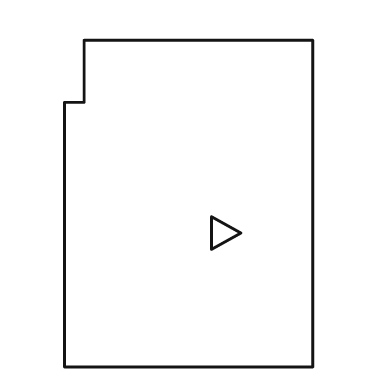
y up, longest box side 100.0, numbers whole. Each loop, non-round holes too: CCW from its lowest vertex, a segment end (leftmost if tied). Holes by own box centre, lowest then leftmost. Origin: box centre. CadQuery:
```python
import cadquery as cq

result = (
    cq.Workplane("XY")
    .moveTo(-38.0, -50.0)
    .lineTo(38.0, -50.0)
    .lineTo(38.0, 50.0)
    .lineTo(-32.0, 50.0)
    .lineTo(-32.0, 31.0)
    .lineTo(-38.0, 31.0)
    .close()
    .moveTo(7.0, -14.0)
    .lineTo(16.0, -9.0)
    .lineTo(7.0, -4.0)
    .close()
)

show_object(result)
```